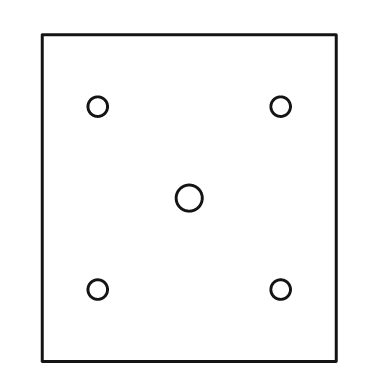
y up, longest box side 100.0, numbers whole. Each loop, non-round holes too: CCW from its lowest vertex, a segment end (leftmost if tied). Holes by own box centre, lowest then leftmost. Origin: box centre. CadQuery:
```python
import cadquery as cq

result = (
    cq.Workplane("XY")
    .moveTo(-45.0, -50.0)
    .lineTo(45.0, -50.0)
    .lineTo(45.0, 50.0)
    .lineTo(-45.0, 50.0)
    .close()
    .moveTo(-28.0, -28.0)
    .circle(3.0)
    .moveTo(28.0, -28.0)
    .circle(3.0)
    .moveTo(0.0, 0.0)
    .circle(4.0)
    .moveTo(-28.0, 28.0)
    .circle(3.0)
    .moveTo(28.0, 28.0)
    .circle(3.0)
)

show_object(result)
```